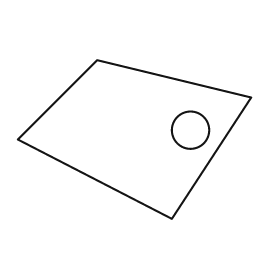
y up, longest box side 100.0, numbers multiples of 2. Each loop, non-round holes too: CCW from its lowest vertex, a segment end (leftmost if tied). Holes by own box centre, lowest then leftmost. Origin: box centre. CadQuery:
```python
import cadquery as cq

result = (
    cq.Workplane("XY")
    .moveTo(16.0, -34.0)
    .lineTo(50.0, 18.0)
    .lineTo(-16.0, 34.0)
    .lineTo(-50.0, 0.0)
    .close()
    .moveTo(24.0, 4.0)
    .circle(8.0)
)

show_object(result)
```